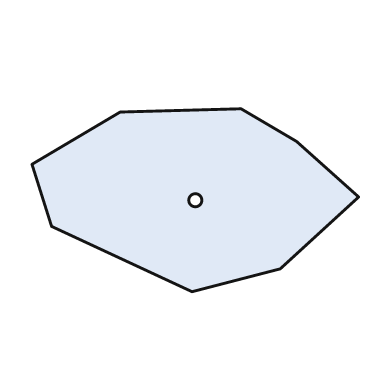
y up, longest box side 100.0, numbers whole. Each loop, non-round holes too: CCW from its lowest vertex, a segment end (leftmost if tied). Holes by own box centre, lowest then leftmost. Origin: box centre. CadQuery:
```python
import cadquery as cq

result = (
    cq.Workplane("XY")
    .moveTo(-1.0, -28.0)
    .lineTo(26.0, -21.0)
    .lineTo(50.0, 1.0)
    .lineTo(31.0, 18.0)
    .lineTo(14.0, 28.0)
    .lineTo(-23.0, 27.0)
    .lineTo(-50.0, 11.0)
    .lineTo(-44.0, -8.0)
    .close()
    .moveTo(0.0, 0.0)
    .circle(2.0)
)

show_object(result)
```